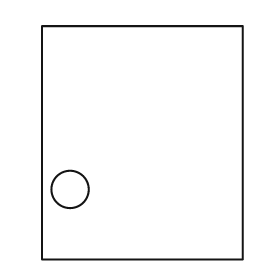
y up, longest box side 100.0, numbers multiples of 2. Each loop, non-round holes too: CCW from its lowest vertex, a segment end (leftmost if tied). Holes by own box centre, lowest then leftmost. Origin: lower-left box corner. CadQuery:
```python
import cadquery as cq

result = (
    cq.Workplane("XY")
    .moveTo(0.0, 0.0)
    .lineTo(86.0, 0.0)
    .lineTo(86.0, 100.0)
    .lineTo(0.0, 100.0)
    .close()
    .moveTo(12.0, 30.0)
    .circle(8.0)
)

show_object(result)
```